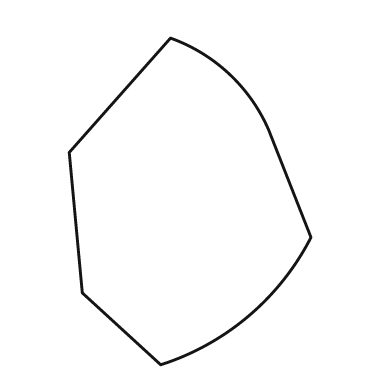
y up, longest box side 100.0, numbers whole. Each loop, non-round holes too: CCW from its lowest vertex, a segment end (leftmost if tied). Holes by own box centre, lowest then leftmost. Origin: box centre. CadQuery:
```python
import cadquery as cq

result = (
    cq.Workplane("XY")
    .moveTo(-9.0, -50.0)
    .threePointArc((18.0, -35.0), (37.0, -11.0))
    .lineTo(24.0, 22.0)
    .threePointArc((12.0, 39.0), (-6.0, 50.0))
    .lineTo(-37.0, 15.0)
    .lineTo(-33.0, -28.0)
    .close()
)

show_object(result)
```